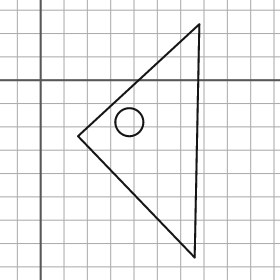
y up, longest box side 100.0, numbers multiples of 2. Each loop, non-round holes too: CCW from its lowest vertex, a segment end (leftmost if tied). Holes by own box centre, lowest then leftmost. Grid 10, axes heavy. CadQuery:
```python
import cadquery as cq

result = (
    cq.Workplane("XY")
    .moveTo(66.0, -76.0)
    .lineTo(68.0, 24.0)
    .lineTo(16.0, -24.0)
    .close()
    .moveTo(38.0, -18.0)
    .circle(6.0)
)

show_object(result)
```